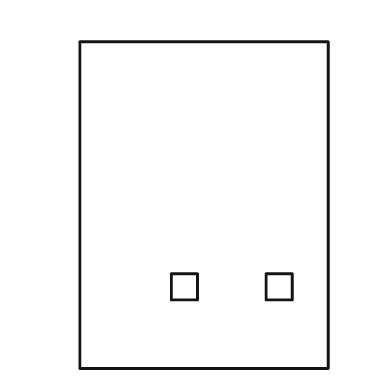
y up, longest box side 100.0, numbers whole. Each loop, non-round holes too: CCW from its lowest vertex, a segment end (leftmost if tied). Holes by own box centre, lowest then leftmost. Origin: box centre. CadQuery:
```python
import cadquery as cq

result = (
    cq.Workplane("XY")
    .moveTo(-38.0, -50.0)
    .lineTo(38.0, -50.0)
    .lineTo(38.0, 50.0)
    .lineTo(-38.0, 50.0)
    .close()
    .moveTo(-10.0, -29.0)
    .lineTo(-2.0, -29.0)
    .lineTo(-2.0, -21.0)
    .lineTo(-10.0, -21.0)
    .close()
    .moveTo(19.0, -29.0)
    .lineTo(27.0, -29.0)
    .lineTo(27.0, -21.0)
    .lineTo(19.0, -21.0)
    .close()
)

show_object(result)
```